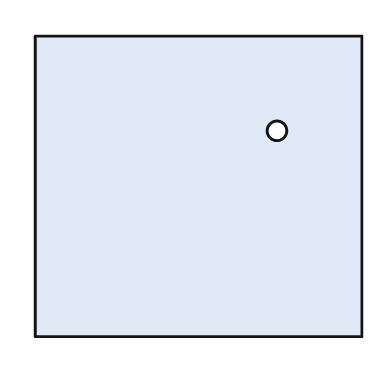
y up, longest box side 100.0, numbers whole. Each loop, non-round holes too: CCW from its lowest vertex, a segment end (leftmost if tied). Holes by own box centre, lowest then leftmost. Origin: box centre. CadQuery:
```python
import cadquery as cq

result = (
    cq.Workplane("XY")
    .moveTo(-50.0, -46.0)
    .lineTo(50.0, -46.0)
    .lineTo(50.0, 46.0)
    .lineTo(-50.0, 46.0)
    .close()
    .moveTo(24.0, 17.0)
    .circle(3.0)
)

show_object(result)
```